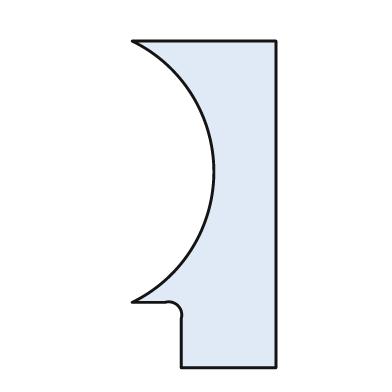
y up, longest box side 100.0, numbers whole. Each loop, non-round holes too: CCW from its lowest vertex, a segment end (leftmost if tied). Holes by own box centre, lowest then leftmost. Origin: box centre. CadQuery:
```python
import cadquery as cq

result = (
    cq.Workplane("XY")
    .moveTo(-7.0, -50.0)
    .lineTo(22.0, -50.0)
    .lineTo(22.0, 50.0)
    .lineTo(-22.0, 50.0)
    .threePointArc((3.0, 10.0), (-22.0, -30.0))
    .lineTo(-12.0, -30.0)
    .threePointArc((-8.0, -31.0), (-7.0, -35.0))
    .close()
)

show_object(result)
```